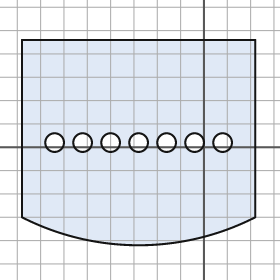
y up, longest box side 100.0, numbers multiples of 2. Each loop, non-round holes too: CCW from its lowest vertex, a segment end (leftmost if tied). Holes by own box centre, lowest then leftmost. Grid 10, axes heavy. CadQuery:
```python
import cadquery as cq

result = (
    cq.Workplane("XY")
    .moveTo(-78.0, -30.0)
    .threePointArc((-28.0, -42.0), (22.0, -30.0))
    .lineTo(22.0, 46.0)
    .lineTo(-78.0, 46.0)
    .close()
    .moveTo(-64.0, 2.0)
    .circle(4.0)
    .moveTo(-52.0, 2.0)
    .circle(4.0)
    .moveTo(-40.0, 2.0)
    .circle(4.0)
    .moveTo(-28.0, 2.0)
    .circle(4.0)
    .moveTo(-16.0, 2.0)
    .circle(4.0)
    .moveTo(-4.0, 2.0)
    .circle(4.0)
    .moveTo(8.0, 2.0)
    .circle(4.0)
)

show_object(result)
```